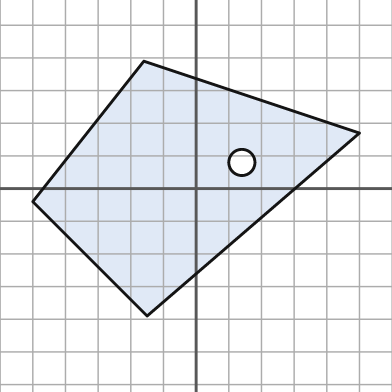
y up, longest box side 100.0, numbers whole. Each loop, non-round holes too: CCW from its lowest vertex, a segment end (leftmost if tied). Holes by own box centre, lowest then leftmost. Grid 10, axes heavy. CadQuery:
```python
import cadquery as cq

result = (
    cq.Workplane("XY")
    .moveTo(-15.0, -39.0)
    .lineTo(50.0, 17.0)
    .lineTo(-16.0, 39.0)
    .lineTo(-50.0, -4.0)
    .close()
    .moveTo(14.0, 8.0)
    .circle(4.0)
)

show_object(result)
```